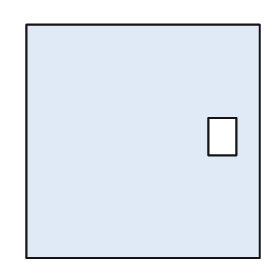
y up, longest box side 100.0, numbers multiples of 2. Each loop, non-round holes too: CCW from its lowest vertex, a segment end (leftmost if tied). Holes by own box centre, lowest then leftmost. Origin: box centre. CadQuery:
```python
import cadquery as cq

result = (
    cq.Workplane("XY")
    .moveTo(-50.0, -50.0)
    .lineTo(50.0, -50.0)
    .lineTo(50.0, 50.0)
    .lineTo(-50.0, 50.0)
    .close()
    .moveTo(28.0, -6.0)
    .lineTo(40.0, -6.0)
    .lineTo(40.0, 10.0)
    .lineTo(28.0, 10.0)
    .close()
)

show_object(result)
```